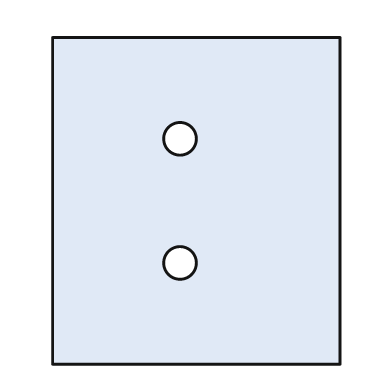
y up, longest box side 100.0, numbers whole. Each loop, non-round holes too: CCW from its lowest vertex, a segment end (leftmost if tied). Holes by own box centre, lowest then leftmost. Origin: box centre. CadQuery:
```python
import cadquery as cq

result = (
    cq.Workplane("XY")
    .moveTo(-44.0, -50.0)
    .lineTo(44.0, -50.0)
    .lineTo(44.0, 50.0)
    .lineTo(-44.0, 50.0)
    .close()
    .moveTo(-5.0, -19.0)
    .circle(5.0)
    .moveTo(-5.0, 19.0)
    .circle(5.0)
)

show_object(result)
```